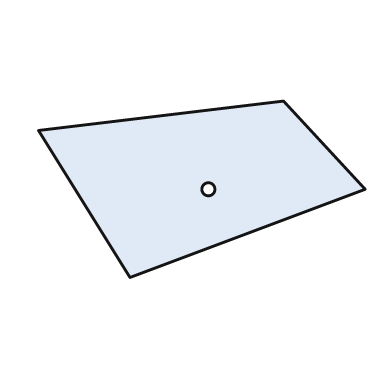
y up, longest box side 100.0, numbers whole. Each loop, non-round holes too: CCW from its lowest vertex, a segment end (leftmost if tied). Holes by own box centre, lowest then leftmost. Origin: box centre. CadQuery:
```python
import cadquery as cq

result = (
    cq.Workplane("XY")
    .moveTo(-22.0, -27.0)
    .lineTo(50.0, 0.0)
    .lineTo(25.0, 27.0)
    .lineTo(-50.0, 18.0)
    .close()
    .moveTo(2.0, 0.0)
    .circle(2.0)
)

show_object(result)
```